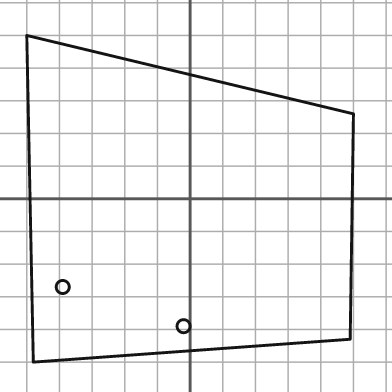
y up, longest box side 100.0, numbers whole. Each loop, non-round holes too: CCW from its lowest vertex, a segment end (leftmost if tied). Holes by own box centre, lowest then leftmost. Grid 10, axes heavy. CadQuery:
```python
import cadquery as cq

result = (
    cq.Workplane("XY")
    .moveTo(-48.0, -50.0)
    .lineTo(49.0, -43.0)
    .lineTo(50.0, 26.0)
    .lineTo(-50.0, 50.0)
    .close()
    .moveTo(-2.0, -39.0)
    .circle(2.0)
    .moveTo(-39.0, -27.0)
    .circle(2.0)
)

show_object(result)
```